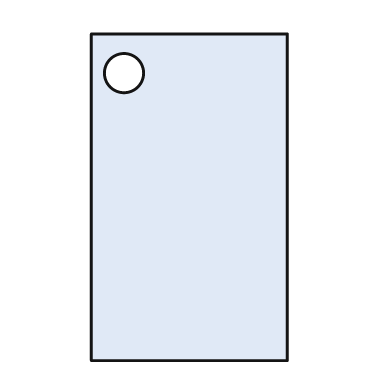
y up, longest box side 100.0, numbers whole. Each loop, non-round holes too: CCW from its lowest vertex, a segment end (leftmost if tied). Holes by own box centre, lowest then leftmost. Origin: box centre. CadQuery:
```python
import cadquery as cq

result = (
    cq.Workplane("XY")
    .moveTo(-30.0, -50.0)
    .lineTo(30.0, -50.0)
    .lineTo(30.0, 50.0)
    .lineTo(-30.0, 50.0)
    .close()
    .moveTo(-20.0, 38.0)
    .circle(6.0)
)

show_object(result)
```